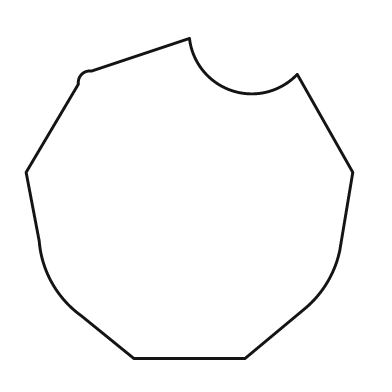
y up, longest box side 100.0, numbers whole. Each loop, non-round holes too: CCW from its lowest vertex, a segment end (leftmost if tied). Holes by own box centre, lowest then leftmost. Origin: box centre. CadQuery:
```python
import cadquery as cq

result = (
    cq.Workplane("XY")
    .moveTo(-17.0, -49.0)
    .lineTo(17.0, -49.0)
    .lineTo(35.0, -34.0)
    .threePointArc((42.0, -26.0), (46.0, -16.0))
    .lineTo(50.0, 8.0)
    .lineTo(33.0, 38.0)
    .threePointArc((13.0, 33.0), (0.0, 49.0))
    .lineTo(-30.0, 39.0)
    .threePointArc((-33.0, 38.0), (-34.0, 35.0))
    .lineTo(-50.0, 8.0)
    .lineTo(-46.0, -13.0)
    .threePointArc((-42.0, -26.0), (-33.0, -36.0))
    .close()
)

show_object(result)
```